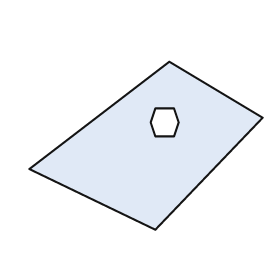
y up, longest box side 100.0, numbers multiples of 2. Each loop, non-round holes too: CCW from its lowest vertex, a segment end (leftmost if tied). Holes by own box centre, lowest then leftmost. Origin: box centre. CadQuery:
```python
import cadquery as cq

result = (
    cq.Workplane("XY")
    .moveTo(4.0, -36.0)
    .lineTo(50.0, 12.0)
    .lineTo(10.0, 36.0)
    .lineTo(-50.0, -10.0)
    .close()
    .moveTo(4.0, 4.0)
    .lineTo(12.0, 4.0)
    .lineTo(14.0, 10.0)
    .lineTo(12.0, 16.0)
    .lineTo(4.0, 16.0)
    .lineTo(2.0, 10.0)
    .close()
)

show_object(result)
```